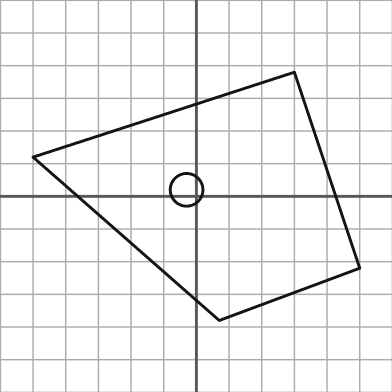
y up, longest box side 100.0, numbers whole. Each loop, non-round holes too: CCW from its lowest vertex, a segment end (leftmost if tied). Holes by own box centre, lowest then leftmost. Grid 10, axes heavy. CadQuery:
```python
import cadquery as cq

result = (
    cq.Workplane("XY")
    .moveTo(7.0, -38.0)
    .lineTo(50.0, -22.0)
    .lineTo(30.0, 38.0)
    .lineTo(-50.0, 12.0)
    .close()
    .moveTo(-3.0, 2.0)
    .circle(5.0)
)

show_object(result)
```